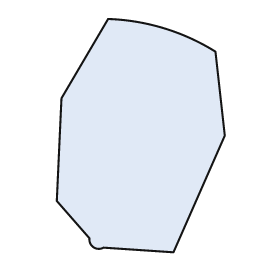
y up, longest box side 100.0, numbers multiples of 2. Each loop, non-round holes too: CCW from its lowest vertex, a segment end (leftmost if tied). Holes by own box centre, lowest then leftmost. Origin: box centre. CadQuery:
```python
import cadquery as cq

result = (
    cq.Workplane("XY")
    .moveTo(14.0, -50.0)
    .lineTo(36.0, 0.0)
    .lineTo(32.0, 36.0)
    .threePointArc((10.0, 46.0), (-14.0, 50.0))
    .lineTo(-34.0, 16.0)
    .lineTo(-36.0, -28.0)
    .lineTo(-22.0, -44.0)
    .threePointArc((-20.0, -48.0), (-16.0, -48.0))
    .close()
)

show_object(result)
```